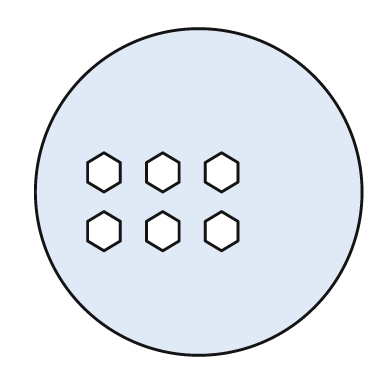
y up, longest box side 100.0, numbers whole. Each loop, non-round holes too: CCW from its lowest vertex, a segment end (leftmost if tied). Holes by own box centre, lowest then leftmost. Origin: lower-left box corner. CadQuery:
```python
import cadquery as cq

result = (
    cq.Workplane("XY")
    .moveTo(50.0, 50.0)
    .circle(50.0)
    .moveTo(21.0, 32.0)
    .lineTo(26.0, 35.0)
    .lineTo(26.0, 41.0)
    .lineTo(21.0, 44.0)
    .lineTo(16.0, 41.0)
    .lineTo(16.0, 35.0)
    .close()
    .moveTo(39.0, 32.0)
    .lineTo(44.0, 35.0)
    .lineTo(44.0, 41.0)
    .lineTo(39.0, 44.0)
    .lineTo(34.0, 41.0)
    .lineTo(34.0, 35.0)
    .close()
    .moveTo(57.0, 32.0)
    .lineTo(62.0, 35.0)
    .lineTo(62.0, 41.0)
    .lineTo(57.0, 44.0)
    .lineTo(52.0, 41.0)
    .lineTo(52.0, 35.0)
    .close()
    .moveTo(21.0, 50.0)
    .lineTo(26.0, 53.0)
    .lineTo(26.0, 59.0)
    .lineTo(21.0, 62.0)
    .lineTo(16.0, 59.0)
    .lineTo(16.0, 53.0)
    .close()
    .moveTo(39.0, 50.0)
    .lineTo(44.0, 53.0)
    .lineTo(44.0, 59.0)
    .lineTo(39.0, 62.0)
    .lineTo(34.0, 59.0)
    .lineTo(34.0, 53.0)
    .close()
    .moveTo(57.0, 50.0)
    .lineTo(62.0, 53.0)
    .lineTo(62.0, 59.0)
    .lineTo(57.0, 62.0)
    .lineTo(52.0, 59.0)
    .lineTo(52.0, 53.0)
    .close()
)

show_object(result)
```